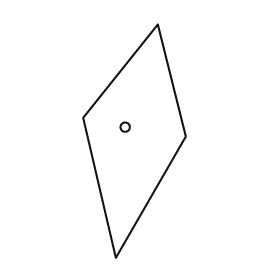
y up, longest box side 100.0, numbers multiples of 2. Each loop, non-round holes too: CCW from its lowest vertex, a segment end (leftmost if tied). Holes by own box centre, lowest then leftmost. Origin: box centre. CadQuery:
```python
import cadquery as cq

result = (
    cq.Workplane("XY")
    .moveTo(-8.0, -50.0)
    .lineTo(22.0, 2.0)
    .lineTo(10.0, 50.0)
    .lineTo(-22.0, 10.0)
    .close()
    .moveTo(-4.0, 6.0)
    .circle(2.0)
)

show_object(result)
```